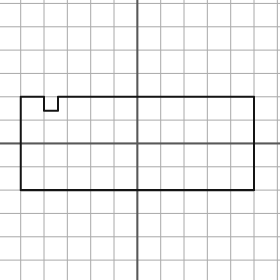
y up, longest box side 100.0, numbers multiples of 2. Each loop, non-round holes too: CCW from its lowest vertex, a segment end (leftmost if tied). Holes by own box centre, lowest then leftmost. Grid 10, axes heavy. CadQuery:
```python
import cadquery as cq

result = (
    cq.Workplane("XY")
    .moveTo(-50.0, -20.0)
    .lineTo(50.0, -20.0)
    .lineTo(50.0, 20.0)
    .lineTo(-34.0, 20.0)
    .lineTo(-34.0, 14.0)
    .lineTo(-40.0, 14.0)
    .lineTo(-40.0, 20.0)
    .lineTo(-50.0, 20.0)
    .close()
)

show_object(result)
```